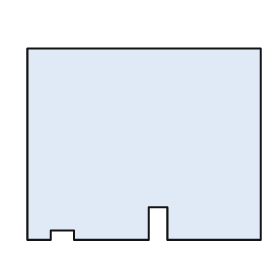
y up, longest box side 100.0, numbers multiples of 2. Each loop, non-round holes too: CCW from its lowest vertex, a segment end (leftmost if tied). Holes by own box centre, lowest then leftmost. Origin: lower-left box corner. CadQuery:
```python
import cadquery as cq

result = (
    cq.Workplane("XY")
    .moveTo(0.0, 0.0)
    .lineTo(10.0, 0.0)
    .lineTo(10.0, 4.0)
    .lineTo(20.0, 4.0)
    .lineTo(20.0, 0.0)
    .lineTo(52.0, 0.0)
    .lineTo(52.0, 14.0)
    .lineTo(60.0, 14.0)
    .lineTo(60.0, 0.0)
    .lineTo(100.0, 0.0)
    .lineTo(100.0, 82.0)
    .lineTo(0.0, 82.0)
    .close()
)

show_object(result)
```